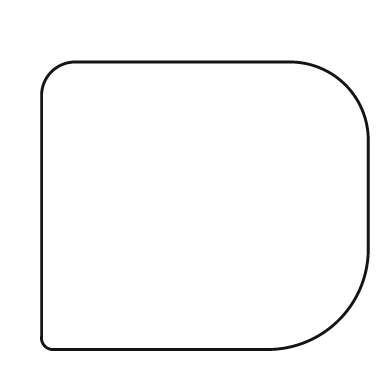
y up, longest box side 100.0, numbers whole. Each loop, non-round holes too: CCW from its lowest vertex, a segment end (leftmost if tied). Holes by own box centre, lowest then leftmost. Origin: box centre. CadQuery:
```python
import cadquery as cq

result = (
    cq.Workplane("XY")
    .moveTo(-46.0, -44.0)
    .lineTo(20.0, -44.0)
    .threePointArc((41.0, -35.0), (50.0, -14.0))
    .lineTo(50.0, 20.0)
    .threePointArc((43.0, 37.0), (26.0, 44.0))
    .lineTo(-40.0, 44.0)
    .threePointArc((-47.0, 41.0), (-50.0, 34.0))
    .lineTo(-50.0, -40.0)
    .threePointArc((-49.0, -43.0), (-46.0, -44.0))
    .close()
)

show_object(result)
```